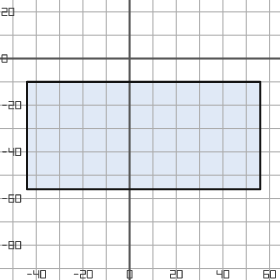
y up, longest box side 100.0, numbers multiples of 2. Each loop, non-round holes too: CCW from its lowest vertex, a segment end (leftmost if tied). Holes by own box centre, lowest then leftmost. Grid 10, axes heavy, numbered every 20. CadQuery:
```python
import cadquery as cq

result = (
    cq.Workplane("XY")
    .moveTo(-44.0, -56.0)
    .lineTo(56.0, -56.0)
    .lineTo(56.0, -10.0)
    .lineTo(-44.0, -10.0)
    .close()
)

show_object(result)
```